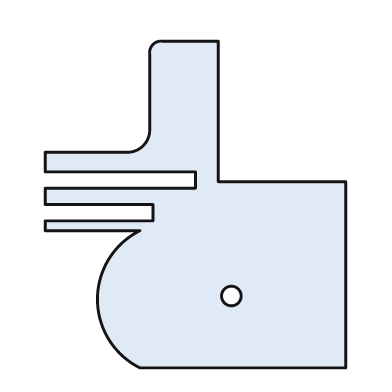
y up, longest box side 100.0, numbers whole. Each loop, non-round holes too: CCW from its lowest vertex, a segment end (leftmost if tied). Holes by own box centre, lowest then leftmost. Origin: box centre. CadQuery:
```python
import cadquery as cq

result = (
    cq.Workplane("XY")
    .moveTo(-17.0, -50.0)
    .lineTo(46.0, -50.0)
    .lineTo(46.0, 7.0)
    .lineTo(7.0, 7.0)
    .lineTo(7.0, 50.0)
    .lineTo(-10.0, 50.0)
    .threePointArc((-13.0, 49.0), (-14.0, 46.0))
    .lineTo(-14.0, 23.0)
    .threePointArc((-16.0, 18.0), (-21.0, 16.0))
    .lineTo(-46.0, 16.0)
    .lineTo(-46.0, 10.0)
    .lineTo(0.0, 10.0)
    .lineTo(0.0, 5.0)
    .lineTo(-46.0, 5.0)
    .lineTo(-46.0, 0.0)
    .lineTo(-13.0, 0.0)
    .lineTo(-13.0, -5.0)
    .lineTo(-46.0, -5.0)
    .lineTo(-46.0, -8.0)
    .lineTo(-17.0, -8.0)
    .threePointArc((-30.0, -29.0), (-17.0, -50.0))
    .close()
    .moveTo(11.0, -28.0)
    .circle(3.0)
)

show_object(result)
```